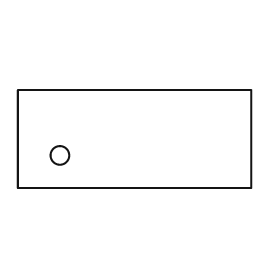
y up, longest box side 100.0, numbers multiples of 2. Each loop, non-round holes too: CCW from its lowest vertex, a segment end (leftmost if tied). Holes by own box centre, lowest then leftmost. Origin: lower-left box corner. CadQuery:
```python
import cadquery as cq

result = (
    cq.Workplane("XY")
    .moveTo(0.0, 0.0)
    .lineTo(100.0, 0.0)
    .lineTo(100.0, 42.0)
    .lineTo(0.0, 42.0)
    .close()
    .moveTo(18.0, 14.0)
    .circle(4.0)
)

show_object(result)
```